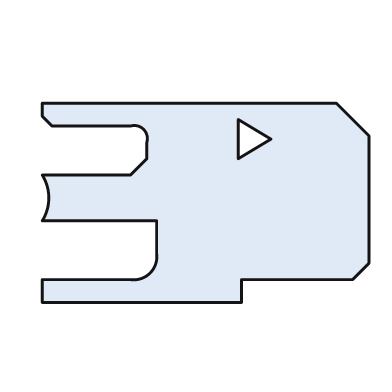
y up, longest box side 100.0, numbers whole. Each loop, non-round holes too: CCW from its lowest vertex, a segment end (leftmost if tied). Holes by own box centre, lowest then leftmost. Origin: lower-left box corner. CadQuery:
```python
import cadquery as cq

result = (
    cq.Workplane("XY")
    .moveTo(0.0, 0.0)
    .lineTo(61.0, 0.0)
    .lineTo(61.0, 7.0)
    .lineTo(95.0, 7.0)
    .lineTo(100.0, 12.0)
    .lineTo(100.0, 51.0)
    .lineTo(90.0, 61.0)
    .lineTo(0.0, 61.0)
    .lineTo(0.0, 57.0)
    .lineTo(3.0, 54.0)
    .lineTo(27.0, 54.0)
    .threePointArc((31.0, 53.0), (32.0, 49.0))
    .lineTo(32.0, 44.0)
    .lineTo(27.0, 39.0)
    .lineTo(0.0, 39.0)
    .threePointArc((2.0, 32.0), (0.0, 25.0))
    .lineTo(35.0, 25.0)
    .lineTo(35.0, 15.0)
    .threePointArc((33.0, 9.0), (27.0, 7.0))
    .lineTo(0.0, 7.0)
    .close()
    .moveTo(60.0, 44.0)
    .lineTo(70.0, 50.0)
    .lineTo(60.0, 56.0)
    .close()
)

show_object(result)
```